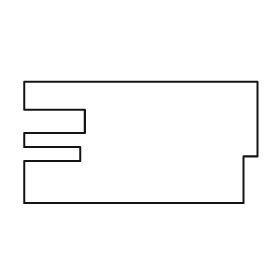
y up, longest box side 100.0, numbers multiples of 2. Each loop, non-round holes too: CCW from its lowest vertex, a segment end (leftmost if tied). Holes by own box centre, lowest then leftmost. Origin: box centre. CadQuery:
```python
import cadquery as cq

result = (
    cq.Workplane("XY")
    .moveTo(-50.0, -26.0)
    .lineTo(44.0, -26.0)
    .lineTo(44.0, -6.0)
    .lineTo(50.0, -6.0)
    .lineTo(50.0, 26.0)
    .lineTo(-50.0, 26.0)
    .lineTo(-50.0, 14.0)
    .lineTo(-24.0, 14.0)
    .lineTo(-24.0, 4.0)
    .lineTo(-50.0, 4.0)
    .lineTo(-50.0, -2.0)
    .lineTo(-26.0, -2.0)
    .lineTo(-26.0, -8.0)
    .lineTo(-50.0, -8.0)
    .close()
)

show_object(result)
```